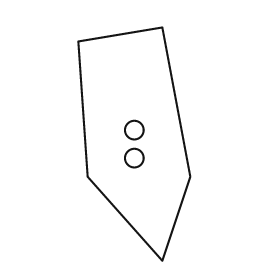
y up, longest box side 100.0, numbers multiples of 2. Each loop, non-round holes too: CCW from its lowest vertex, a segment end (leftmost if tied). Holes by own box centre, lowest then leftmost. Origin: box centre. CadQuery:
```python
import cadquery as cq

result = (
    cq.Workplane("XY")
    .moveTo(12.0, -50.0)
    .lineTo(24.0, -14.0)
    .lineTo(12.0, 50.0)
    .lineTo(-24.0, 44.0)
    .lineTo(-20.0, -14.0)
    .close()
    .moveTo(0.0, -6.0)
    .circle(4.0)
    .moveTo(0.0, 6.0)
    .circle(4.0)
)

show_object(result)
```